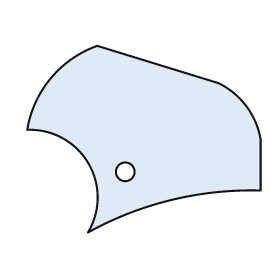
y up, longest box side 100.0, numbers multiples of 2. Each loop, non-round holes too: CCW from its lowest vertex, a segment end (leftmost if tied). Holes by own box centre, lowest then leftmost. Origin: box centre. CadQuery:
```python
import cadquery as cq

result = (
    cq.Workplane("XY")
    .moveTo(-24.0, -40.0)
    .threePointArc((12.0, -26.0), (50.0, -22.0))
    .lineTo(50.0, 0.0)
    .threePointArc((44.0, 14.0), (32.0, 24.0))
    .lineTo(-20.0, 40.0)
    .threePointArc((-40.0, 26.0), (-50.0, 4.0))
    .threePointArc((-24.0, -10.0), (-24.0, -40.0))
    .close()
    .moveTo(-8.0, -14.0)
    .circle(4.0)
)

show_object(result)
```